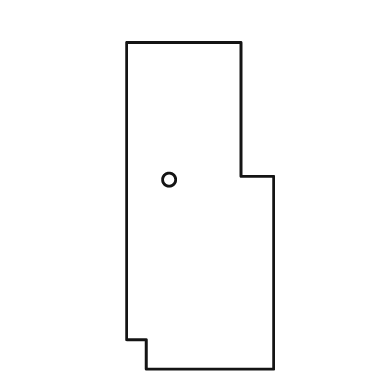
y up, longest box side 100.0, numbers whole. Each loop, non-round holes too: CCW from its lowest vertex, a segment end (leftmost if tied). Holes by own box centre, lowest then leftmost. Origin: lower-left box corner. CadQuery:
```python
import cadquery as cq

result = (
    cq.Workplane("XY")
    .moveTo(6.0, 0.0)
    .lineTo(45.0, 0.0)
    .lineTo(45.0, 59.0)
    .lineTo(35.0, 59.0)
    .lineTo(35.0, 100.0)
    .lineTo(0.0, 100.0)
    .lineTo(0.0, 9.0)
    .lineTo(6.0, 9.0)
    .close()
    .moveTo(13.0, 58.0)
    .circle(2.0)
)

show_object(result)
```